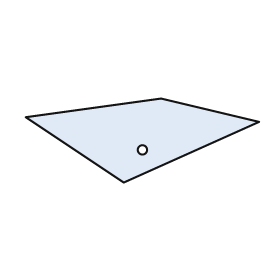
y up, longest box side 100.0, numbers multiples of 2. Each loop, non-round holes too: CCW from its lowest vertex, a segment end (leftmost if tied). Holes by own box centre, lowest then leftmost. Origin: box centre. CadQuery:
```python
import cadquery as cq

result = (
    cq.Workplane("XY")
    .moveTo(-8.0, -18.0)
    .lineTo(50.0, 8.0)
    .lineTo(8.0, 18.0)
    .lineTo(-50.0, 10.0)
    .close()
    .moveTo(0.0, -4.0)
    .circle(2.0)
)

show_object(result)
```